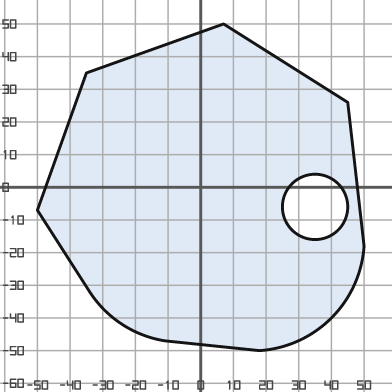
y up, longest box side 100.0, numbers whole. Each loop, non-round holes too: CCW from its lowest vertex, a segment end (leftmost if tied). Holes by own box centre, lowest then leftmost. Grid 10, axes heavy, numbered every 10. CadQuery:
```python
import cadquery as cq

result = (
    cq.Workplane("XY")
    .moveTo(18.0, -50.0)
    .threePointArc((40.0, -40.0), (50.0, -18.0))
    .lineTo(45.0, 26.0)
    .lineTo(7.0, 50.0)
    .lineTo(-35.0, 35.0)
    .lineTo(-50.0, -7.0)
    .lineTo(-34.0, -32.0)
    .threePointArc((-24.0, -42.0), (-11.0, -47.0))
    .close()
    .moveTo(35.0, -6.0)
    .circle(10.0)
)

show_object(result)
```